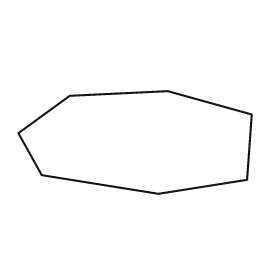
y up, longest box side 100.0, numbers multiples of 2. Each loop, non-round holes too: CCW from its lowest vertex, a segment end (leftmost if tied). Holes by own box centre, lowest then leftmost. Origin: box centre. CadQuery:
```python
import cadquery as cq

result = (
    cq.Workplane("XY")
    .moveTo(10.0, -22.0)
    .lineTo(48.0, -16.0)
    .lineTo(50.0, 12.0)
    .lineTo(14.0, 22.0)
    .lineTo(-28.0, 20.0)
    .lineTo(-50.0, 4.0)
    .lineTo(-40.0, -14.0)
    .close()
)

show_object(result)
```